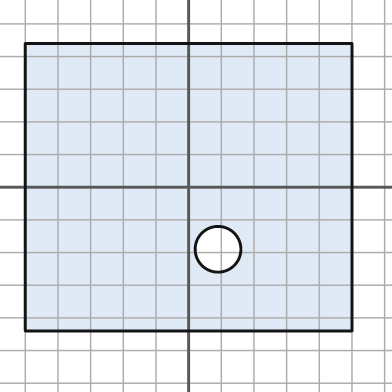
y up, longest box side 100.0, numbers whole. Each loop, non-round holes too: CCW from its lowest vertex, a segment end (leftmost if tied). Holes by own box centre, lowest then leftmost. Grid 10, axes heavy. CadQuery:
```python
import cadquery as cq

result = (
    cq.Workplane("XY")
    .moveTo(-50.0, -44.0)
    .lineTo(50.0, -44.0)
    .lineTo(50.0, 44.0)
    .lineTo(-50.0, 44.0)
    .close()
    .moveTo(9.0, -19.0)
    .circle(7.0)
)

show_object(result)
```